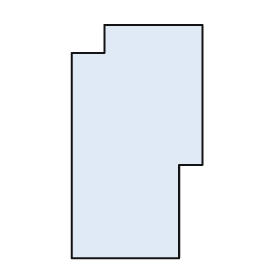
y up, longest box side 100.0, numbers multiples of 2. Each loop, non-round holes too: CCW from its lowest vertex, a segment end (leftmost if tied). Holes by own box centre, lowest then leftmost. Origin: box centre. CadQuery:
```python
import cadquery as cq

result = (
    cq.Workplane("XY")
    .moveTo(-28.0, -50.0)
    .lineTo(18.0, -50.0)
    .lineTo(18.0, -10.0)
    .lineTo(28.0, -10.0)
    .lineTo(28.0, 50.0)
    .lineTo(-14.0, 50.0)
    .lineTo(-14.0, 38.0)
    .lineTo(-28.0, 38.0)
    .close()
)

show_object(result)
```